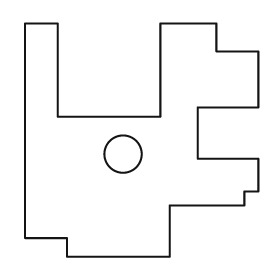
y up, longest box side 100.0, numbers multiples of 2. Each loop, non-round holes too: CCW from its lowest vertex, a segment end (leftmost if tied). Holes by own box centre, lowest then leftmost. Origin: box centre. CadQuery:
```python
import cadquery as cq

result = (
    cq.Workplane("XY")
    .moveTo(-32.0, -50.0)
    .lineTo(12.0, -50.0)
    .lineTo(12.0, -28.0)
    .lineTo(44.0, -28.0)
    .lineTo(44.0, -22.0)
    .lineTo(50.0, -22.0)
    .lineTo(50.0, -8.0)
    .lineTo(24.0, -8.0)
    .lineTo(24.0, 14.0)
    .lineTo(50.0, 14.0)
    .lineTo(50.0, 38.0)
    .lineTo(32.0, 38.0)
    .lineTo(32.0, 50.0)
    .lineTo(8.0, 50.0)
    .lineTo(8.0, 10.0)
    .lineTo(-36.0, 10.0)
    .lineTo(-36.0, 50.0)
    .lineTo(-50.0, 50.0)
    .lineTo(-50.0, -42.0)
    .lineTo(-32.0, -42.0)
    .close()
    .moveTo(-8.0, -6.0)
    .circle(8.0)
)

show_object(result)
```